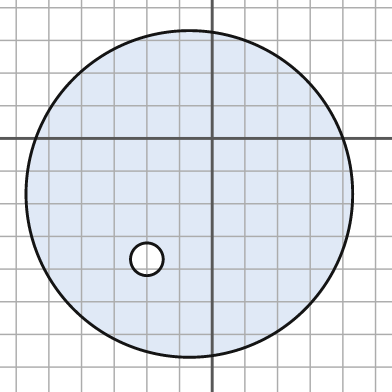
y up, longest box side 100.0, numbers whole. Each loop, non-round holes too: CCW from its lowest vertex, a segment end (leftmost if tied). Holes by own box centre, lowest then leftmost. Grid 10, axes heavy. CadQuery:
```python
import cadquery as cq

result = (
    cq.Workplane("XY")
    .moveTo(-7.0, -17.0)
    .circle(50.0)
    .moveTo(-20.0, -37.0)
    .circle(5.0)
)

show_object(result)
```